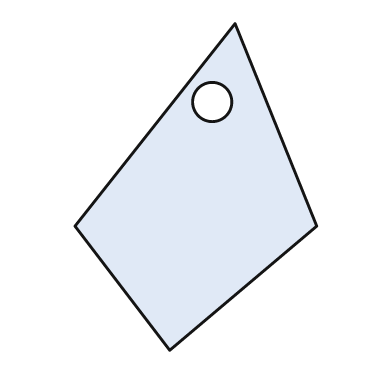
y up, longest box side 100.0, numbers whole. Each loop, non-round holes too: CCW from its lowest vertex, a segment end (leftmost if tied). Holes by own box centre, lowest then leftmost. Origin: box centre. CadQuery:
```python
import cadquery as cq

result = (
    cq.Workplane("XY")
    .moveTo(-8.0, -50.0)
    .lineTo(37.0, -12.0)
    .lineTo(12.0, 50.0)
    .lineTo(-37.0, -12.0)
    .close()
    .moveTo(5.0, 26.0)
    .circle(6.0)
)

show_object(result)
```